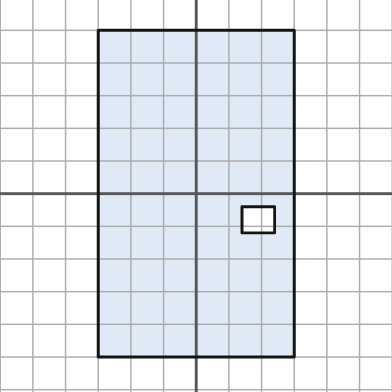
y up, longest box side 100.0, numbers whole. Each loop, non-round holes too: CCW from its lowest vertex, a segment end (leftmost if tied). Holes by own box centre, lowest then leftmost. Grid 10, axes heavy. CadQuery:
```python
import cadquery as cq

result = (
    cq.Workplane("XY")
    .moveTo(-30.0, -50.0)
    .lineTo(30.0, -50.0)
    .lineTo(30.0, 50.0)
    .lineTo(-30.0, 50.0)
    .close()
    .moveTo(14.0, -12.0)
    .lineTo(24.0, -12.0)
    .lineTo(24.0, -4.0)
    .lineTo(14.0, -4.0)
    .close()
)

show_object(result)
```